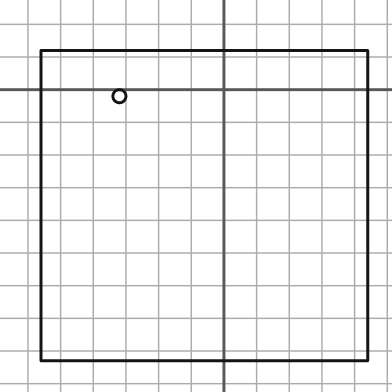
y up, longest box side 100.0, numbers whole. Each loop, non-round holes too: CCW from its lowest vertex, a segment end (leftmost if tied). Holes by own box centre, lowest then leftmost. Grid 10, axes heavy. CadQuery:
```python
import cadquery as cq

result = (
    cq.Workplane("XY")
    .moveTo(-56.0, -83.0)
    .lineTo(44.0, -83.0)
    .lineTo(44.0, 12.0)
    .lineTo(-56.0, 12.0)
    .close()
    .moveTo(-32.0, -2.0)
    .circle(2.0)
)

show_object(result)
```